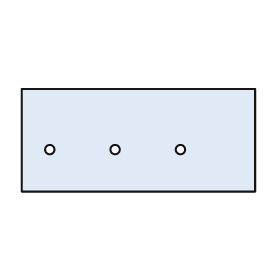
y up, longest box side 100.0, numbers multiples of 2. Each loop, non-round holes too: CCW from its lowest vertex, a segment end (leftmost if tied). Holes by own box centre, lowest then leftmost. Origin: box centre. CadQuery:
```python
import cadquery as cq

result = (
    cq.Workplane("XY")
    .moveTo(-50.0, -22.0)
    .lineTo(50.0, -22.0)
    .lineTo(50.0, 22.0)
    .lineTo(-50.0, 22.0)
    .close()
    .moveTo(-38.0, -4.0)
    .circle(2.0)
    .moveTo(-10.0, -4.0)
    .circle(2.0)
    .moveTo(18.0, -4.0)
    .circle(2.0)
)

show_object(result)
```